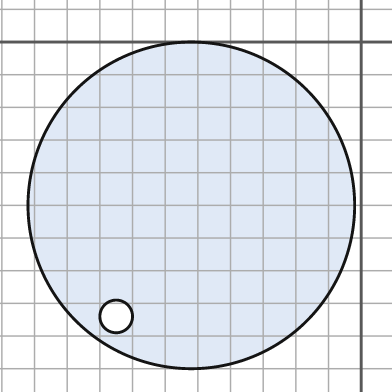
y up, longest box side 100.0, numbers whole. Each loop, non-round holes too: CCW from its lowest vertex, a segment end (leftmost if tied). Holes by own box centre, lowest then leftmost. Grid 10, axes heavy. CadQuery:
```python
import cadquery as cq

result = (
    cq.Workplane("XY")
    .moveTo(-52.0, -50.0)
    .circle(50.0)
    .moveTo(-75.0, -84.0)
    .circle(5.0)
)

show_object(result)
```